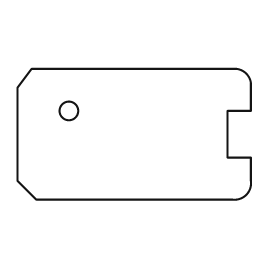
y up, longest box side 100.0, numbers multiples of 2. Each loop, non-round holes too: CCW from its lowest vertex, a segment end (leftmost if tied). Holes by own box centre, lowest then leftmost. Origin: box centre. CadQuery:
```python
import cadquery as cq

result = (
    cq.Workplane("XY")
    .moveTo(-42.0, -28.0)
    .lineTo(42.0, -28.0)
    .threePointArc((48.0, -26.0), (50.0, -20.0))
    .lineTo(50.0, -10.0)
    .lineTo(40.0, -10.0)
    .lineTo(40.0, 10.0)
    .lineTo(50.0, 10.0)
    .lineTo(50.0, 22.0)
    .threePointArc((48.0, 26.0), (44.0, 28.0))
    .lineTo(-44.0, 28.0)
    .lineTo(-50.0, 20.0)
    .lineTo(-50.0, -20.0)
    .close()
    .moveTo(-28.0, 10.0)
    .circle(4.0)
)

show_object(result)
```